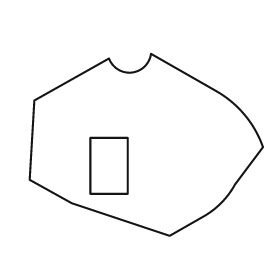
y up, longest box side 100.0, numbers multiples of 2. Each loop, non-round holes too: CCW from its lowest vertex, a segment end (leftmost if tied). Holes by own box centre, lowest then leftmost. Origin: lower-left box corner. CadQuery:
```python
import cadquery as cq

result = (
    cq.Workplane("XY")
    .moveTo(60.0, 0.0)
    .lineTo(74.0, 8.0)
    .threePointArc((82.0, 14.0), (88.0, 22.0))
    .lineTo(100.0, 38.0)
    .threePointArc((92.0, 52.0), (80.0, 62.0))
    .lineTo(52.0, 78.0)
    .threePointArc((44.0, 70.0), (34.0, 76.0))
    .lineTo(2.0, 58.0)
    .lineTo(0.0, 24.0)
    .lineTo(18.0, 14.0)
    .close()
    .moveTo(26.0, 18.0)
    .lineTo(42.0, 18.0)
    .lineTo(42.0, 42.0)
    .lineTo(26.0, 42.0)
    .close()
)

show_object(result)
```